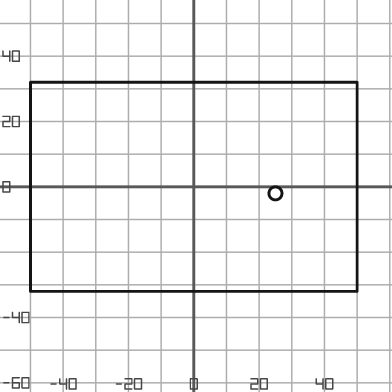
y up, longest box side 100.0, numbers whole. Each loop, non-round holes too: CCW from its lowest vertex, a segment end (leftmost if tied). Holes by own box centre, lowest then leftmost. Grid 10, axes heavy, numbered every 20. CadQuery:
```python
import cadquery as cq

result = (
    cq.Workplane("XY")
    .moveTo(-50.0, -32.0)
    .lineTo(50.0, -32.0)
    .lineTo(50.0, 32.0)
    .lineTo(-50.0, 32.0)
    .close()
    .moveTo(25.0, -2.0)
    .circle(2.0)
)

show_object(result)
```